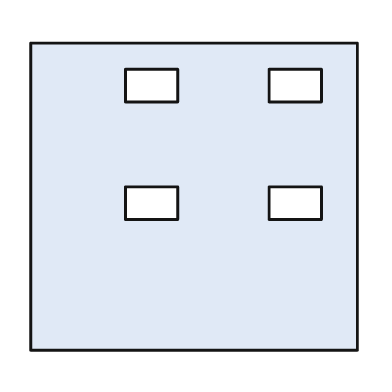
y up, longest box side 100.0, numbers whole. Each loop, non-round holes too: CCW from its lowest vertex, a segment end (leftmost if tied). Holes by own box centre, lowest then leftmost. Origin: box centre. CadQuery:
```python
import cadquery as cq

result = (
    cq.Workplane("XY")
    .moveTo(-50.0, -47.0)
    .lineTo(50.0, -47.0)
    .lineTo(50.0, 47.0)
    .lineTo(-50.0, 47.0)
    .close()
    .moveTo(-21.0, -7.0)
    .lineTo(-5.0, -7.0)
    .lineTo(-5.0, 3.0)
    .lineTo(-21.0, 3.0)
    .close()
    .moveTo(23.0, -7.0)
    .lineTo(39.0, -7.0)
    .lineTo(39.0, 3.0)
    .lineTo(23.0, 3.0)
    .close()
    .moveTo(-21.0, 29.0)
    .lineTo(-5.0, 29.0)
    .lineTo(-5.0, 39.0)
    .lineTo(-21.0, 39.0)
    .close()
    .moveTo(23.0, 29.0)
    .lineTo(39.0, 29.0)
    .lineTo(39.0, 39.0)
    .lineTo(23.0, 39.0)
    .close()
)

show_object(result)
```